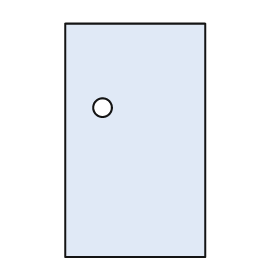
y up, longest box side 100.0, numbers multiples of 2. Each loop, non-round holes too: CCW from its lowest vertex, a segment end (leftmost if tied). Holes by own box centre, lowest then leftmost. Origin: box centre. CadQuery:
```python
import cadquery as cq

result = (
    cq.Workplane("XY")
    .moveTo(-30.0, -50.0)
    .lineTo(30.0, -50.0)
    .lineTo(30.0, 50.0)
    .lineTo(-30.0, 50.0)
    .close()
    .moveTo(-14.0, 14.0)
    .circle(4.0)
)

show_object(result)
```